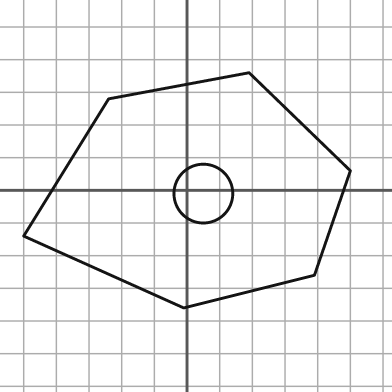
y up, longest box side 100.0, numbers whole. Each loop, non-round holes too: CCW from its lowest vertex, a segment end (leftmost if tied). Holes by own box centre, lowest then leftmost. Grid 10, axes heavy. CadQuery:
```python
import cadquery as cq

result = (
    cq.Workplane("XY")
    .moveTo(-1.0, -36.0)
    .lineTo(39.0, -26.0)
    .lineTo(50.0, 6.0)
    .lineTo(19.0, 36.0)
    .lineTo(-24.0, 28.0)
    .lineTo(-50.0, -14.0)
    .close()
    .moveTo(5.0, -1.0)
    .circle(9.0)
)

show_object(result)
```